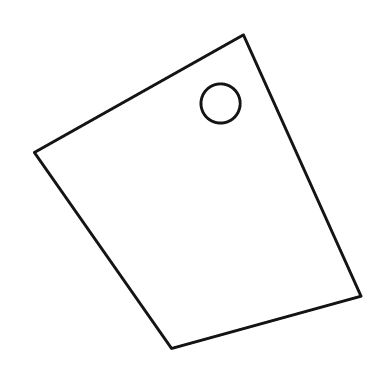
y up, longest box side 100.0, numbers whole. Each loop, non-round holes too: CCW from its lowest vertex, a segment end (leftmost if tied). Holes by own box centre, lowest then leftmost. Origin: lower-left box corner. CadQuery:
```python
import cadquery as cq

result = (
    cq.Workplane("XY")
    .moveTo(42.0, 0.0)
    .lineTo(100.0, 16.0)
    .lineTo(64.0, 96.0)
    .lineTo(0.0, 60.0)
    .close()
    .moveTo(57.0, 75.0)
    .circle(6.0)
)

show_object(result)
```